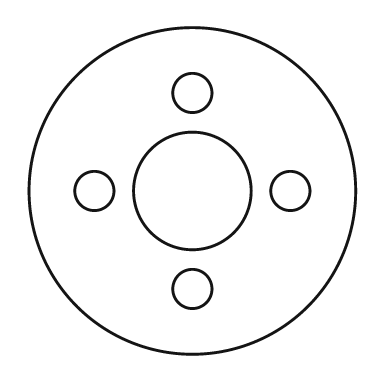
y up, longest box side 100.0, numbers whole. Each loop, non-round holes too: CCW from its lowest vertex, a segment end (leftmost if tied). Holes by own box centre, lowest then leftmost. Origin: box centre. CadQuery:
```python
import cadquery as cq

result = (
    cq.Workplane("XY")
    .moveTo(0.0, 0.0)
    .circle(50.0)
    .moveTo(0.0, -30.0)
    .circle(6.0)
    .moveTo(-30.0, 0.0)
    .circle(6.0)
    .moveTo(0.0, 0.0)
    .circle(18.0)
    .moveTo(30.0, 0.0)
    .circle(6.0)
    .moveTo(0.0, 30.0)
    .circle(6.0)
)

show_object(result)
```